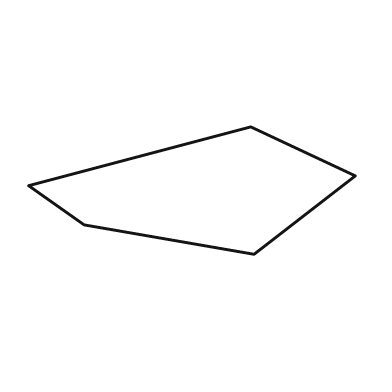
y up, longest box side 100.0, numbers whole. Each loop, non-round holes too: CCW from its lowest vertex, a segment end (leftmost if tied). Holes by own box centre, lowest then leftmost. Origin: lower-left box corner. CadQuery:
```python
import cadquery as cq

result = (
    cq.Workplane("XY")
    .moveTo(69.0, 0.0)
    .lineTo(100.0, 24.0)
    .lineTo(68.0, 39.0)
    .lineTo(0.0, 21.0)
    .lineTo(17.0, 9.0)
    .close()
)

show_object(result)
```